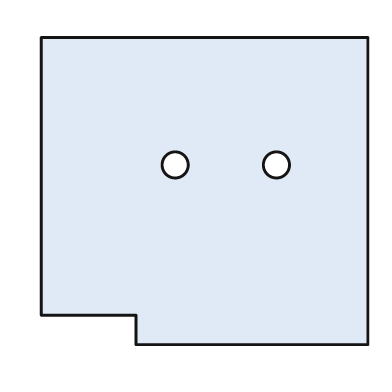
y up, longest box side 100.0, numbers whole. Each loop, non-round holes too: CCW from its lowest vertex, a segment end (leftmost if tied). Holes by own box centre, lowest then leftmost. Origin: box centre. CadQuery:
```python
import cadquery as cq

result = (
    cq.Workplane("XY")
    .moveTo(-21.0, -47.0)
    .lineTo(50.0, -47.0)
    .lineTo(50.0, 47.0)
    .lineTo(-50.0, 47.0)
    .lineTo(-50.0, -38.0)
    .lineTo(-21.0, -38.0)
    .close()
    .moveTo(-9.0, 8.0)
    .circle(4.0)
    .moveTo(22.0, 8.0)
    .circle(4.0)
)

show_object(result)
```